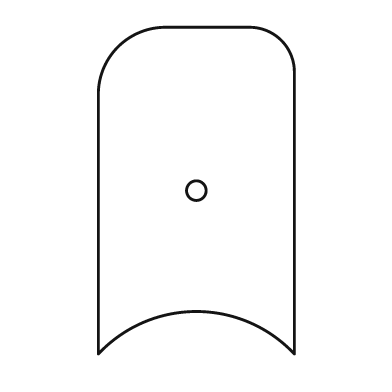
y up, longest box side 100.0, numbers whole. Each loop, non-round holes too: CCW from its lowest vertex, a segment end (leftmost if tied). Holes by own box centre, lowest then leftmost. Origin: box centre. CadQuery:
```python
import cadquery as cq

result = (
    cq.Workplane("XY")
    .moveTo(-30.0, -50.0)
    .threePointArc((0.0, -37.0), (30.0, -50.0))
    .lineTo(30.0, 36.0)
    .threePointArc((26.0, 46.0), (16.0, 50.0))
    .lineTo(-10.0, 50.0)
    .threePointArc((-24.0, 44.0), (-30.0, 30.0))
    .close()
    .moveTo(0.0, 0.0)
    .circle(3.0)
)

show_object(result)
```